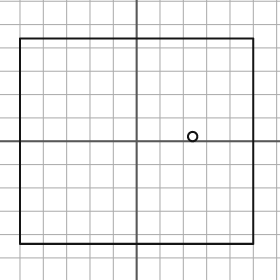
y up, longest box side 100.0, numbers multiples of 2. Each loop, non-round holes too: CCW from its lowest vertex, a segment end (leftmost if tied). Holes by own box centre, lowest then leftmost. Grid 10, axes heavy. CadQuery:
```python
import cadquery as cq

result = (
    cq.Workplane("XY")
    .moveTo(-50.0, -44.0)
    .lineTo(50.0, -44.0)
    .lineTo(50.0, 44.0)
    .lineTo(-50.0, 44.0)
    .close()
    .moveTo(24.0, 2.0)
    .circle(2.0)
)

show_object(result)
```